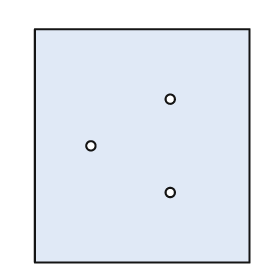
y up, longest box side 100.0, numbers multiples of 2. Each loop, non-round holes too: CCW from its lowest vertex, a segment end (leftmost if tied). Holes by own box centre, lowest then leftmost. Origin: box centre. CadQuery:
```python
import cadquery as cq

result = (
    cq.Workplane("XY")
    .moveTo(-46.0, -50.0)
    .lineTo(46.0, -50.0)
    .lineTo(46.0, 50.0)
    .lineTo(-46.0, 50.0)
    .close()
    .moveTo(12.0, -20.0)
    .circle(2.0)
    .moveTo(-22.0, 0.0)
    .circle(2.0)
    .moveTo(12.0, 20.0)
    .circle(2.0)
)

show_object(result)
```